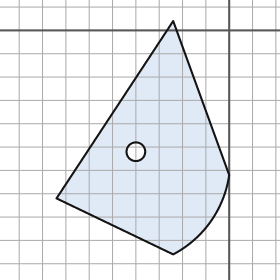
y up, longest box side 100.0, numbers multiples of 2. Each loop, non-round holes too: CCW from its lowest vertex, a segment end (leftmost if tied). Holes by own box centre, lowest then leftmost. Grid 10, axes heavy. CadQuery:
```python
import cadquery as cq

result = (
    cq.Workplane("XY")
    .moveTo(-24.0, -96.0)
    .threePointArc((-8.0, -82.0), (0.0, -62.0))
    .lineTo(-24.0, 4.0)
    .lineTo(-74.0, -72.0)
    .close()
    .moveTo(-40.0, -52.0)
    .circle(4.0)
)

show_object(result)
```